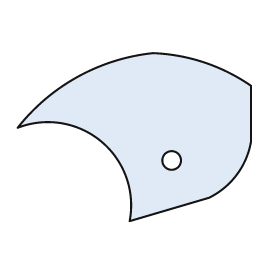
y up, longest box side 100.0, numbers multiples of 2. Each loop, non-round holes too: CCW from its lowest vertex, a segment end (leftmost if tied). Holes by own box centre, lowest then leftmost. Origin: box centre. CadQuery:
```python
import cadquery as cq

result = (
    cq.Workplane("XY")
    .moveTo(-2.0, -36.0)
    .lineTo(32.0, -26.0)
    .threePointArc((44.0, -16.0), (50.0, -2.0))
    .lineTo(50.0, 22.0)
    .threePointArc((30.0, 32.0), (8.0, 36.0))
    .threePointArc((-24.0, 26.0), (-50.0, 4.0))
    .threePointArc((-14.0, -2.0), (-2.0, -36.0))
    .close()
    .moveTo(16.0, -10.0)
    .circle(4.0)
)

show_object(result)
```